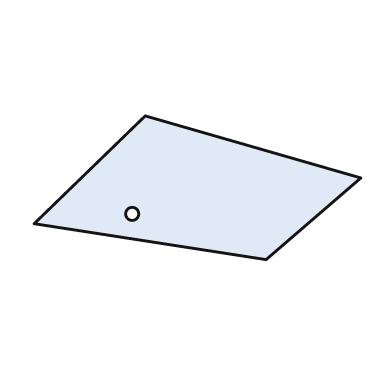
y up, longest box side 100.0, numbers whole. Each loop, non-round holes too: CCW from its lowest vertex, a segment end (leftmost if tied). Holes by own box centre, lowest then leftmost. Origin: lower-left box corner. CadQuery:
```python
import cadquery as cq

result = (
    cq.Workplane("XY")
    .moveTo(71.0, 0.0)
    .lineTo(100.0, 25.0)
    .lineTo(34.0, 44.0)
    .lineTo(0.0, 11.0)
    .close()
    .moveTo(30.0, 14.0)
    .circle(2.0)
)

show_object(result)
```